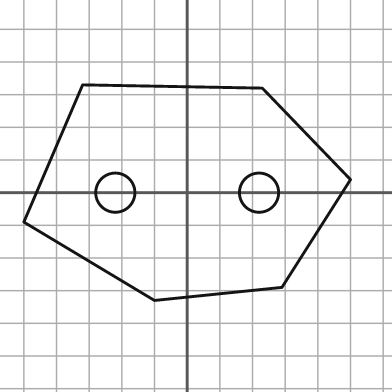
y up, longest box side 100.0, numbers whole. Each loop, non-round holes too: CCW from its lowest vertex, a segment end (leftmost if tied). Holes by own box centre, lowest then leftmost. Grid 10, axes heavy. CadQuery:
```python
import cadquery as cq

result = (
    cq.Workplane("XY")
    .moveTo(-10.0, -33.0)
    .lineTo(29.0, -29.0)
    .lineTo(50.0, 4.0)
    .lineTo(23.0, 32.0)
    .lineTo(-32.0, 33.0)
    .lineTo(-50.0, -9.0)
    .close()
    .moveTo(-22.0, 0.0)
    .circle(6.0)
    .moveTo(22.0, 0.0)
    .circle(6.0)
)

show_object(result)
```